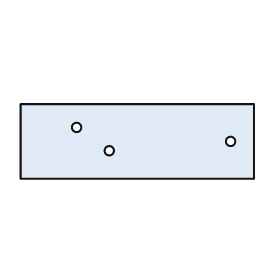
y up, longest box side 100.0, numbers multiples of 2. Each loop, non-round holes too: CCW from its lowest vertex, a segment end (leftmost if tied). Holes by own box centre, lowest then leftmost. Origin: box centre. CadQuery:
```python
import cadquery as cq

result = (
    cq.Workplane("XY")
    .moveTo(-50.0, -16.0)
    .lineTo(50.0, -16.0)
    .lineTo(50.0, 16.0)
    .lineTo(-50.0, 16.0)
    .close()
    .moveTo(-12.0, -4.0)
    .circle(2.0)
    .moveTo(40.0, 0.0)
    .circle(2.0)
    .moveTo(-26.0, 6.0)
    .circle(2.0)
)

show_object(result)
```